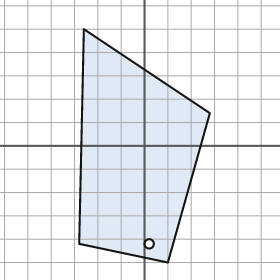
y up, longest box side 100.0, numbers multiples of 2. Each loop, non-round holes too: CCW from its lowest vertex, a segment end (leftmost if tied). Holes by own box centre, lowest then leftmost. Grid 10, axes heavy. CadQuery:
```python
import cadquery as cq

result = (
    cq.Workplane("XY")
    .moveTo(10.0, -50.0)
    .lineTo(28.0, 14.0)
    .lineTo(-26.0, 50.0)
    .lineTo(-28.0, -42.0)
    .close()
    .moveTo(2.0, -42.0)
    .circle(2.0)
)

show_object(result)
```